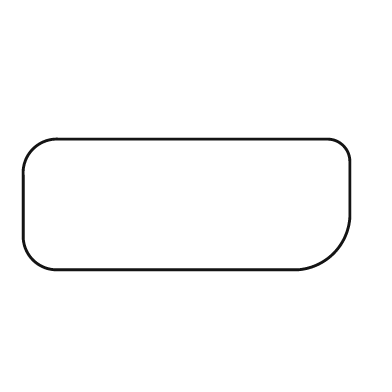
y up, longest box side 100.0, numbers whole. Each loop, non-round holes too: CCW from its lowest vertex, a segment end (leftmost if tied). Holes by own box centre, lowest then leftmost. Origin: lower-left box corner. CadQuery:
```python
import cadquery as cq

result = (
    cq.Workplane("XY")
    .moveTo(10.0, 0.0)
    .lineTo(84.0, 0.0)
    .threePointArc((95.0, 5.0), (100.0, 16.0))
    .lineTo(100.0, 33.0)
    .threePointArc((98.0, 38.0), (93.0, 40.0))
    .lineTo(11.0, 40.0)
    .threePointArc((3.0, 37.0), (0.0, 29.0))
    .lineTo(0.0, 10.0)
    .threePointArc((3.0, 3.0), (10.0, 0.0))
    .close()
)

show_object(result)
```